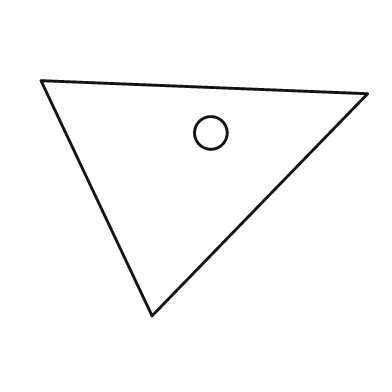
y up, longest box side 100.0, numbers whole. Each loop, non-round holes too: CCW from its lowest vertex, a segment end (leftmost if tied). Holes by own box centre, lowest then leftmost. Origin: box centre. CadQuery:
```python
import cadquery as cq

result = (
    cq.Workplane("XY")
    .moveTo(-16.0, -36.0)
    .lineTo(50.0, 32.0)
    .lineTo(-50.0, 36.0)
    .close()
    .moveTo(2.0, 20.0)
    .circle(5.0)
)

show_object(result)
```